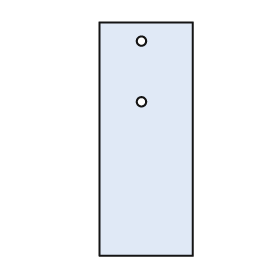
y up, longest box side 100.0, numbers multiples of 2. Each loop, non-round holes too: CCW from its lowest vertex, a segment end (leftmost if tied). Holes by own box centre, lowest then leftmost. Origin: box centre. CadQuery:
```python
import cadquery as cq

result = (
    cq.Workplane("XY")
    .moveTo(-20.0, -50.0)
    .lineTo(20.0, -50.0)
    .lineTo(20.0, 50.0)
    .lineTo(-20.0, 50.0)
    .close()
    .moveTo(-2.0, 16.0)
    .circle(2.0)
    .moveTo(-2.0, 42.0)
    .circle(2.0)
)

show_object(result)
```